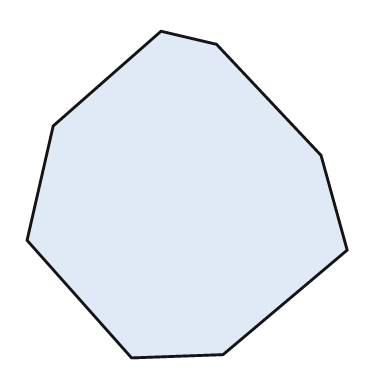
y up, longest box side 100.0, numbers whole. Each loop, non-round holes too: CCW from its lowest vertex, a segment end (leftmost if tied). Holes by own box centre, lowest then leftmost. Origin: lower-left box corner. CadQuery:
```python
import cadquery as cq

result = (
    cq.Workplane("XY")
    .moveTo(32.0, 0.0)
    .lineTo(60.0, 1.0)
    .lineTo(98.0, 33.0)
    .lineTo(90.0, 62.0)
    .lineTo(58.0, 96.0)
    .lineTo(41.0, 100.0)
    .lineTo(8.0, 71.0)
    .lineTo(0.0, 36.0)
    .close()
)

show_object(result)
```